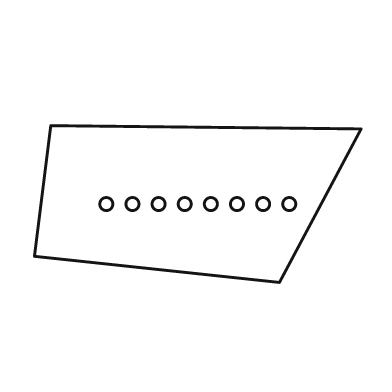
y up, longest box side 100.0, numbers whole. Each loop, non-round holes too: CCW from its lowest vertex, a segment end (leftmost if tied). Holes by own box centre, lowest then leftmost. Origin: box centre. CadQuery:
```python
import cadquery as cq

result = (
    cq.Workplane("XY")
    .moveTo(25.0, -24.0)
    .lineTo(50.0, 23.0)
    .lineTo(-45.0, 24.0)
    .lineTo(-50.0, -16.0)
    .close()
    .moveTo(-28.0, 0.0)
    .circle(2.0)
    .moveTo(-20.0, 0.0)
    .circle(2.0)
    .moveTo(-12.0, 0.0)
    .circle(2.0)
    .moveTo(-4.0, 0.0)
    .circle(2.0)
    .moveTo(4.0, 0.0)
    .circle(2.0)
    .moveTo(12.0, 0.0)
    .circle(2.0)
    .moveTo(20.0, 0.0)
    .circle(2.0)
    .moveTo(28.0, 0.0)
    .circle(2.0)
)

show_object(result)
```